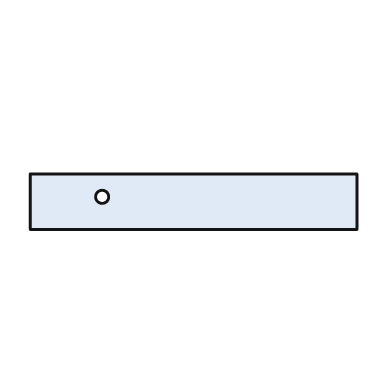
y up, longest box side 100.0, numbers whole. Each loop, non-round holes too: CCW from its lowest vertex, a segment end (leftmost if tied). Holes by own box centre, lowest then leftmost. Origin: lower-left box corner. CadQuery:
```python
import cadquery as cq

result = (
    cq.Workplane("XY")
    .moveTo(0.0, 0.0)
    .lineTo(100.0, 0.0)
    .lineTo(100.0, 17.0)
    .lineTo(0.0, 17.0)
    .close()
    .moveTo(22.0, 10.0)
    .circle(2.0)
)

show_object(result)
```